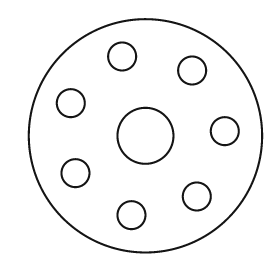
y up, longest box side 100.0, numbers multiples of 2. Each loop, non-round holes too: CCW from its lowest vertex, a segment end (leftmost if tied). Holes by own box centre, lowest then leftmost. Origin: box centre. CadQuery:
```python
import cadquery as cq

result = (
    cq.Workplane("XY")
    .moveTo(0.0, 0.0)
    .circle(50.0)
    .moveTo(-6.0, -34.0)
    .circle(6.0)
    .moveTo(22.0, -26.0)
    .circle(6.0)
    .moveTo(-30.0, -16.0)
    .circle(6.0)
    .moveTo(0.0, 0.0)
    .circle(12.0)
    .moveTo(34.0, 2.0)
    .circle(6.0)
    .moveTo(-32.0, 14.0)
    .circle(6.0)
    .moveTo(20.0, 28.0)
    .circle(6.0)
    .moveTo(-10.0, 34.0)
    .circle(6.0)
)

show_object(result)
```